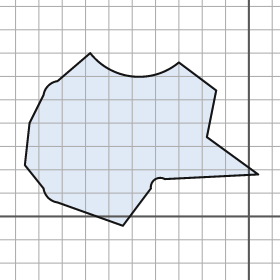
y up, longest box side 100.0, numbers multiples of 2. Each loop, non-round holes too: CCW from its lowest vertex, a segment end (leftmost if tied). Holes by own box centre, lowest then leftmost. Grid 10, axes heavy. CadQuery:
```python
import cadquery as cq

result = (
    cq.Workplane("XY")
    .moveTo(-54.0, -4.0)
    .lineTo(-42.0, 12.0)
    .threePointArc((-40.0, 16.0), (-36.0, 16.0))
    .lineTo(4.0, 18.0)
    .lineTo(-18.0, 34.0)
    .lineTo(-14.0, 54.0)
    .lineTo(-30.0, 66.0)
    .threePointArc((-50.0, 60.0), (-68.0, 70.0))
    .lineTo(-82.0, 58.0)
    .threePointArc((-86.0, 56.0), (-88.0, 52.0))
    .lineTo(-94.0, 40.0)
    .lineTo(-96.0, 22.0)
    .lineTo(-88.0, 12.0)
    .threePointArc((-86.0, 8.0), (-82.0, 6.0))
    .close()
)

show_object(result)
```